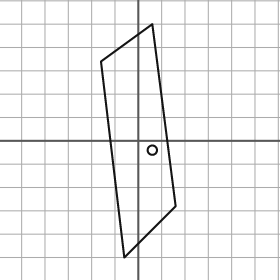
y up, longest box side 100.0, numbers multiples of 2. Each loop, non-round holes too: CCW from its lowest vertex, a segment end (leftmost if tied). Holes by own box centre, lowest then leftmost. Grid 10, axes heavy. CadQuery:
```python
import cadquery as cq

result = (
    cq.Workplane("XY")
    .moveTo(-6.0, -50.0)
    .lineTo(16.0, -28.0)
    .lineTo(6.0, 50.0)
    .lineTo(-16.0, 34.0)
    .close()
    .moveTo(6.0, -4.0)
    .circle(2.0)
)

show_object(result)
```